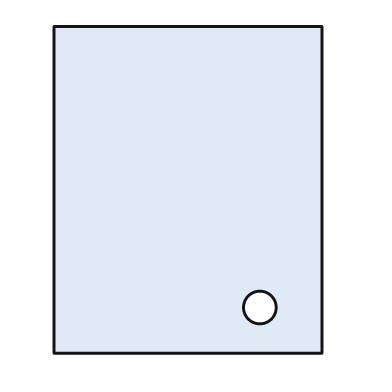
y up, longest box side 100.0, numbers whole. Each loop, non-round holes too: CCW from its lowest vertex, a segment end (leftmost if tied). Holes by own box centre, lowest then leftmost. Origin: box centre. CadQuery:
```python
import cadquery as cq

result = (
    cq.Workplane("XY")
    .moveTo(-41.0, -50.0)
    .lineTo(41.0, -50.0)
    .lineTo(41.0, 50.0)
    .lineTo(-41.0, 50.0)
    .close()
    .moveTo(22.0, -36.0)
    .circle(5.0)
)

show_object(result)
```